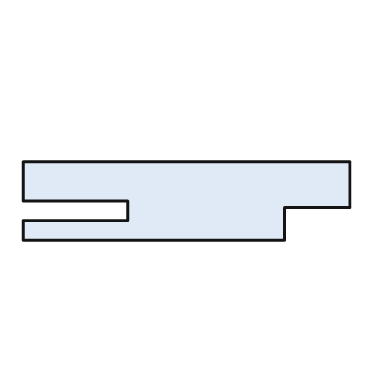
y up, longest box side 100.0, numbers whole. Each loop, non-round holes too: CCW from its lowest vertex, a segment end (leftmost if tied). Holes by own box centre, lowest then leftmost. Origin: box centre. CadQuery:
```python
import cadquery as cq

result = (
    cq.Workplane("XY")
    .moveTo(-50.0, -12.0)
    .lineTo(30.0, -12.0)
    .lineTo(30.0, -2.0)
    .lineTo(50.0, -2.0)
    .lineTo(50.0, 12.0)
    .lineTo(-50.0, 12.0)
    .lineTo(-50.0, 0.0)
    .lineTo(-18.0, 0.0)
    .lineTo(-18.0, -6.0)
    .lineTo(-50.0, -6.0)
    .close()
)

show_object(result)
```